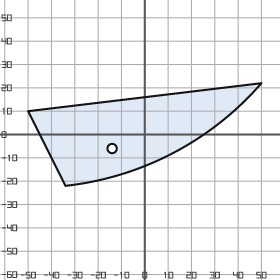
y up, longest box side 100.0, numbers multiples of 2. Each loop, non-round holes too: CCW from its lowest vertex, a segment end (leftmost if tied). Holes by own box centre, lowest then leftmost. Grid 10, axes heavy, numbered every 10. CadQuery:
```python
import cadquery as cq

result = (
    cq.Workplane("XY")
    .moveTo(-34.0, -22.0)
    .threePointArc((12.0, -8.0), (50.0, 22.0))
    .lineTo(-50.0, 10.0)
    .close()
    .moveTo(-14.0, -6.0)
    .circle(2.0)
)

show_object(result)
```